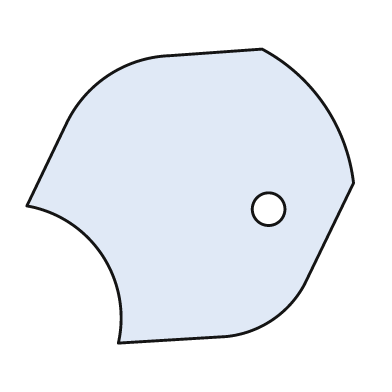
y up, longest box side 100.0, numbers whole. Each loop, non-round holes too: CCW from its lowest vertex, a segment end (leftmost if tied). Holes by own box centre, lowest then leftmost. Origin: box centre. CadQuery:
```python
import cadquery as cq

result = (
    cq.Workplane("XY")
    .moveTo(-22.0, -45.0)
    .lineTo(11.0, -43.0)
    .threePointArc((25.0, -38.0), (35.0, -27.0))
    .lineTo(50.0, 4.0)
    .threePointArc((41.0, 28.0), (22.0, 45.0))
    .lineTo(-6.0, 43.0)
    .threePointArc((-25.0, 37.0), (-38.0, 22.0))
    .lineTo(-50.0, -3.0)
    .threePointArc((-27.0, -18.0), (-22.0, -45.0))
    .close()
    .moveTo(24.0, -4.0)
    .circle(5.0)
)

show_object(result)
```